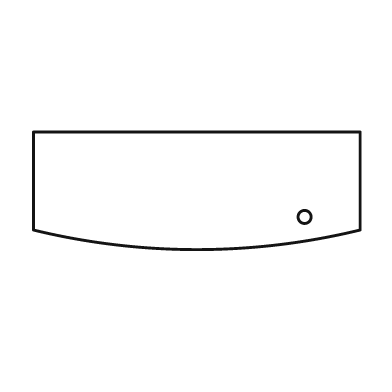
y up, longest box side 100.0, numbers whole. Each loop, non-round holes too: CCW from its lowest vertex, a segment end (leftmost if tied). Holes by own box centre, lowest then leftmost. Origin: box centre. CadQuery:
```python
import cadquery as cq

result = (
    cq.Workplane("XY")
    .moveTo(-50.0, -12.0)
    .threePointArc((0.0, -18.0), (50.0, -12.0))
    .lineTo(50.0, 18.0)
    .lineTo(-50.0, 18.0)
    .close()
    .moveTo(33.0, -8.0)
    .circle(2.0)
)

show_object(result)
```